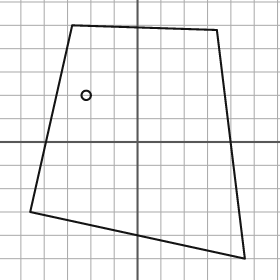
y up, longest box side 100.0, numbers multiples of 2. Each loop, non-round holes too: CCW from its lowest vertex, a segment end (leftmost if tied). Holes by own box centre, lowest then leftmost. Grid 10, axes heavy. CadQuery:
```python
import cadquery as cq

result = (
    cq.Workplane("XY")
    .moveTo(46.0, -50.0)
    .lineTo(34.0, 48.0)
    .lineTo(-28.0, 50.0)
    .lineTo(-46.0, -30.0)
    .close()
    .moveTo(-22.0, 20.0)
    .circle(2.0)
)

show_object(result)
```